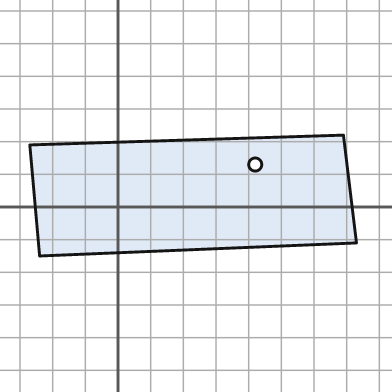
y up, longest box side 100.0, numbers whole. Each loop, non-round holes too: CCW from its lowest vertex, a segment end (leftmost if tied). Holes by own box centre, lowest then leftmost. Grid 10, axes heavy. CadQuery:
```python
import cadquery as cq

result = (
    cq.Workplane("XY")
    .moveTo(-24.0, -15.0)
    .lineTo(73.0, -11.0)
    .lineTo(69.0, 22.0)
    .lineTo(-27.0, 19.0)
    .close()
    .moveTo(42.0, 13.0)
    .circle(2.0)
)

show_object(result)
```